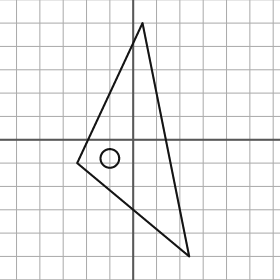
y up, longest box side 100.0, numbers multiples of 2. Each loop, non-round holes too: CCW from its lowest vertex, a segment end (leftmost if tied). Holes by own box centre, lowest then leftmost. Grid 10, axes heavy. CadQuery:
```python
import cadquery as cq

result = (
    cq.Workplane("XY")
    .moveTo(24.0, -50.0)
    .lineTo(4.0, 50.0)
    .lineTo(-24.0, -10.0)
    .close()
    .moveTo(-10.0, -8.0)
    .circle(4.0)
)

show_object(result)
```